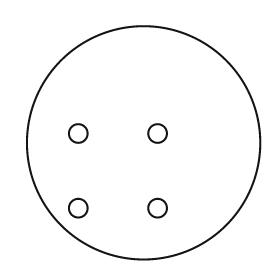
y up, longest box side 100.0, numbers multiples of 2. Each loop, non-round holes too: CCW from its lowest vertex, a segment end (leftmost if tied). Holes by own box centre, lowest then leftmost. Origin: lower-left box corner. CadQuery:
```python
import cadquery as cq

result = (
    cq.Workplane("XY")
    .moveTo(50.0, 50.0)
    .circle(50.0)
    .moveTo(22.0, 22.0)
    .circle(4.0)
    .moveTo(56.0, 22.0)
    .circle(4.0)
    .moveTo(22.0, 54.0)
    .circle(4.0)
    .moveTo(56.0, 54.0)
    .circle(4.0)
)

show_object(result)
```